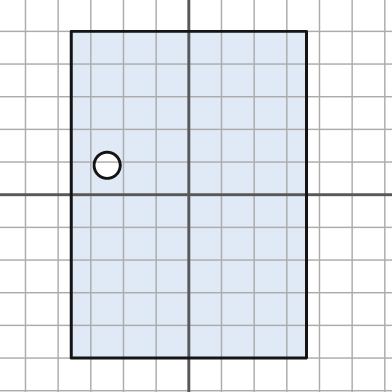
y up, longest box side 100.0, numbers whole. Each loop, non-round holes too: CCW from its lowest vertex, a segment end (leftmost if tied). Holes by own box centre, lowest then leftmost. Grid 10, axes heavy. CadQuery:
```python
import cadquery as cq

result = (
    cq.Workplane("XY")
    .moveTo(-36.0, -50.0)
    .lineTo(36.0, -50.0)
    .lineTo(36.0, 50.0)
    .lineTo(-36.0, 50.0)
    .close()
    .moveTo(-25.0, 9.0)
    .circle(4.0)
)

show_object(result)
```